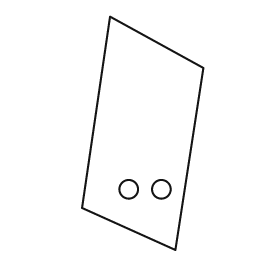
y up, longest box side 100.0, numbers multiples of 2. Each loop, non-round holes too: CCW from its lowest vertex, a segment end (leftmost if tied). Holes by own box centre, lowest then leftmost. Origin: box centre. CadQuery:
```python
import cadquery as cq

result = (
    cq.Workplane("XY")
    .moveTo(14.0, -50.0)
    .lineTo(26.0, 28.0)
    .lineTo(-14.0, 50.0)
    .lineTo(-26.0, -32.0)
    .close()
    .moveTo(-6.0, -24.0)
    .circle(4.0)
    .moveTo(8.0, -24.0)
    .circle(4.0)
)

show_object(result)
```